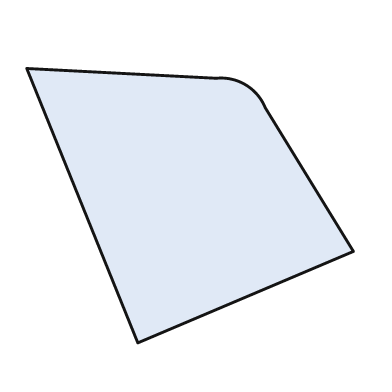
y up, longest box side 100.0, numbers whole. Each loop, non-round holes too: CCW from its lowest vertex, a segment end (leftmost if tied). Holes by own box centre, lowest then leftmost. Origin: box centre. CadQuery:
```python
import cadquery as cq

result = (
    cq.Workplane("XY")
    .moveTo(-16.0, -42.0)
    .lineTo(50.0, -14.0)
    .lineTo(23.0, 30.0)
    .threePointArc((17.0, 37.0), (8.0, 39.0))
    .lineTo(-50.0, 42.0)
    .close()
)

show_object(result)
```